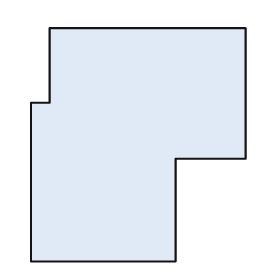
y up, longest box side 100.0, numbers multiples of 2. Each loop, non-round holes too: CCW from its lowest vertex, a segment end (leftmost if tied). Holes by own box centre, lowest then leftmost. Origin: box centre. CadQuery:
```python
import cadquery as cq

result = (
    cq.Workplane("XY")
    .moveTo(-46.0, -50.0)
    .lineTo(16.0, -50.0)
    .lineTo(16.0, -6.0)
    .lineTo(46.0, -6.0)
    .lineTo(46.0, 50.0)
    .lineTo(-38.0, 50.0)
    .lineTo(-38.0, 18.0)
    .lineTo(-46.0, 18.0)
    .close()
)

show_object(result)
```